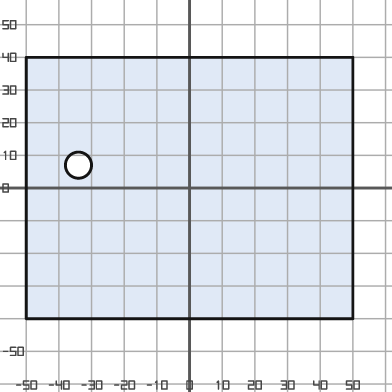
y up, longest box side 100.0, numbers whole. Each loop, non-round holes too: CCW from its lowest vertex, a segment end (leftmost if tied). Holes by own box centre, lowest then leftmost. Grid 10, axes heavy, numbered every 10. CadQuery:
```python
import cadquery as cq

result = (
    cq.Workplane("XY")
    .moveTo(-50.0, -40.0)
    .lineTo(50.0, -40.0)
    .lineTo(50.0, 40.0)
    .lineTo(-50.0, 40.0)
    .close()
    .moveTo(-34.0, 7.0)
    .circle(4.0)
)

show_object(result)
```